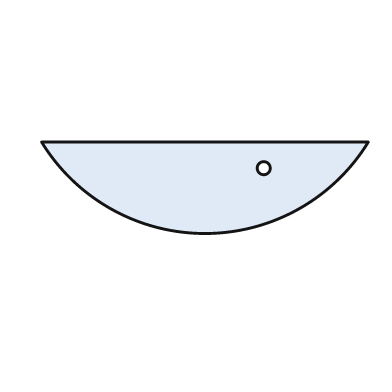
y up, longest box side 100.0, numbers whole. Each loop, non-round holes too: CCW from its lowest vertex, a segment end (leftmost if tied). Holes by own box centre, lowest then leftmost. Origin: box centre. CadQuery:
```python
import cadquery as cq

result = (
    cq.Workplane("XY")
    .moveTo(-50.0, 14.0)
    .threePointArc((0.0, -14.0), (50.0, 14.0))
    .close()
    .moveTo(18.0, 6.0)
    .circle(2.0)
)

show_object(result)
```